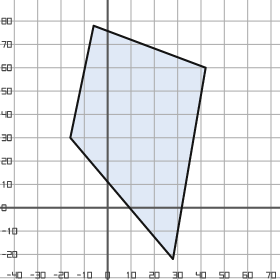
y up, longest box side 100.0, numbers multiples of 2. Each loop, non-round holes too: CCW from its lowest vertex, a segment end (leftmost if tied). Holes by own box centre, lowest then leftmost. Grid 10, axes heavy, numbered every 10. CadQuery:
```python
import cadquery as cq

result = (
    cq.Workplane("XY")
    .moveTo(28.0, -22.0)
    .lineTo(42.0, 60.0)
    .lineTo(-6.0, 78.0)
    .lineTo(-16.0, 30.0)
    .close()
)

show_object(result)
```